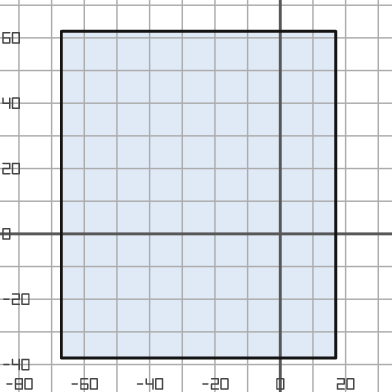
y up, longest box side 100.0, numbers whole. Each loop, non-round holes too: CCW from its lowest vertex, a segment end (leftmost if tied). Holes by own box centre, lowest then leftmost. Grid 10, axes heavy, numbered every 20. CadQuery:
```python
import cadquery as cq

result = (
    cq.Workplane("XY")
    .moveTo(-67.0, -38.0)
    .lineTo(17.0, -38.0)
    .lineTo(17.0, 62.0)
    .lineTo(-67.0, 62.0)
    .close()
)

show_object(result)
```